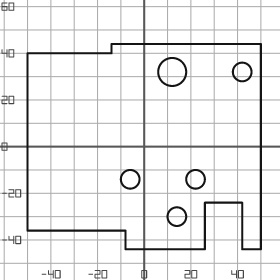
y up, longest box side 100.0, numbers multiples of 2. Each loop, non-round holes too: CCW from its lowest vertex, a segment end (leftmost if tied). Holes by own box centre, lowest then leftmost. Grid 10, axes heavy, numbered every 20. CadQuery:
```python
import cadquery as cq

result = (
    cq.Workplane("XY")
    .moveTo(-8.0, -44.0)
    .lineTo(26.0, -44.0)
    .lineTo(26.0, -24.0)
    .lineTo(42.0, -24.0)
    .lineTo(42.0, -44.0)
    .lineTo(50.0, -44.0)
    .lineTo(50.0, 44.0)
    .lineTo(-14.0, 44.0)
    .lineTo(-14.0, 40.0)
    .lineTo(-50.0, 40.0)
    .lineTo(-50.0, -36.0)
    .lineTo(-8.0, -36.0)
    .close()
    .moveTo(14.0, -30.0)
    .circle(4.0)
    .moveTo(-6.0, -14.0)
    .circle(4.0)
    .moveTo(22.0, -14.0)
    .circle(4.0)
    .moveTo(12.0, 32.0)
    .circle(6.0)
    .moveTo(42.0, 32.0)
    .circle(4.0)
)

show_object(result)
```